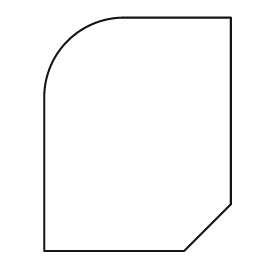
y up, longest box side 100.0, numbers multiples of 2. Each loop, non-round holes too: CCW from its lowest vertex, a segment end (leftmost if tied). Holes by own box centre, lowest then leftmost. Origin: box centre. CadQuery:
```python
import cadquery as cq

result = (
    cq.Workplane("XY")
    .moveTo(-40.0, -50.0)
    .lineTo(20.0, -50.0)
    .lineTo(40.0, -30.0)
    .lineTo(40.0, 50.0)
    .lineTo(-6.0, 50.0)
    .threePointArc((-30.0, 40.0), (-40.0, 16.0))
    .close()
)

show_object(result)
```